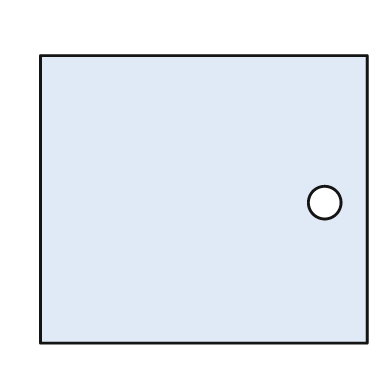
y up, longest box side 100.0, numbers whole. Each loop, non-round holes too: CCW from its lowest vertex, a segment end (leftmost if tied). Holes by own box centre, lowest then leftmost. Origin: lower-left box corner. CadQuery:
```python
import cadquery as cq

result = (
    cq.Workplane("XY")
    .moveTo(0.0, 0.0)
    .lineTo(100.0, 0.0)
    .lineTo(100.0, 88.0)
    .lineTo(0.0, 88.0)
    .close()
    .moveTo(87.0, 43.0)
    .circle(5.0)
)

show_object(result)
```